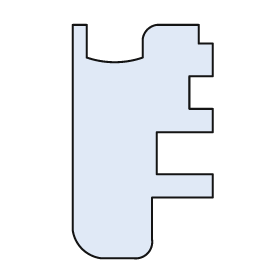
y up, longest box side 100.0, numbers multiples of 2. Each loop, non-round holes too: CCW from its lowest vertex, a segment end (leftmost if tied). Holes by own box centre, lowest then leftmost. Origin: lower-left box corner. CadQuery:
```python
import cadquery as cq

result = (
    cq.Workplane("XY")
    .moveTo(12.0, 0.0)
    .lineTo(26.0, 0.0)
    .threePointArc((32.0, 2.0), (34.0, 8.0))
    .lineTo(34.0, 26.0)
    .lineTo(60.0, 26.0)
    .lineTo(60.0, 36.0)
    .lineTo(36.0, 36.0)
    .lineTo(36.0, 54.0)
    .lineTo(60.0, 54.0)
    .lineTo(60.0, 64.0)
    .lineTo(50.0, 64.0)
    .lineTo(50.0, 78.0)
    .lineTo(60.0, 78.0)
    .lineTo(60.0, 92.0)
    .lineTo(54.0, 92.0)
    .lineTo(54.0, 100.0)
    .lineTo(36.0, 100.0)
    .threePointArc((32.0, 98.0), (30.0, 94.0))
    .lineTo(30.0, 86.0)
    .threePointArc((18.0, 84.0), (6.0, 86.0))
    .lineTo(6.0, 100.0)
    .lineTo(0.0, 100.0)
    .lineTo(0.0, 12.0)
    .threePointArc((4.0, 4.0), (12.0, 0.0))
    .close()
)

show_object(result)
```